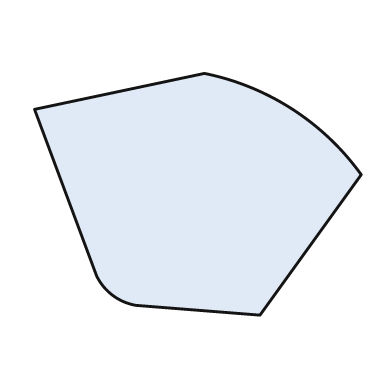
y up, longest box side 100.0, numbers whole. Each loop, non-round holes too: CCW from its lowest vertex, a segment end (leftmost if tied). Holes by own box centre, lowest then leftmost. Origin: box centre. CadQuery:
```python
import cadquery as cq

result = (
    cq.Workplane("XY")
    .moveTo(19.0, -37.0)
    .lineTo(50.0, 6.0)
    .threePointArc((29.0, 26.0), (2.0, 37.0))
    .lineTo(-50.0, 26.0)
    .lineTo(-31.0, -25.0)
    .threePointArc((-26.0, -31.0), (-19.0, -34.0))
    .close()
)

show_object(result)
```